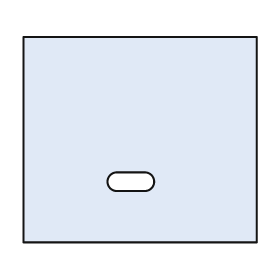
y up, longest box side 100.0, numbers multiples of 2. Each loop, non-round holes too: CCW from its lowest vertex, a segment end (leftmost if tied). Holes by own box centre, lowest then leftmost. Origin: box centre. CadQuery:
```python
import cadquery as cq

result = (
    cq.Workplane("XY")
    .moveTo(-50.0, -44.0)
    .lineTo(50.0, -44.0)
    .lineTo(50.0, 44.0)
    .lineTo(-50.0, 44.0)
    .close()
    .moveTo(-10.0, -22.0)
    .lineTo(2.0, -22.0)
    .threePointArc((6.0, -18.0), (2.0, -14.0))
    .lineTo(-10.0, -14.0)
    .threePointArc((-14.0, -18.0), (-10.0, -22.0))
    .close()
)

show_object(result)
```